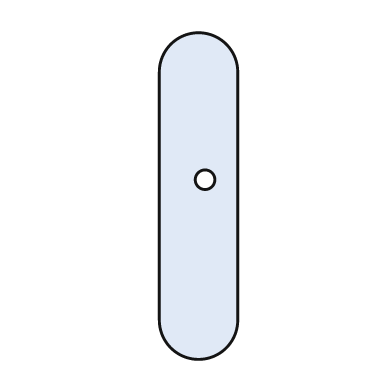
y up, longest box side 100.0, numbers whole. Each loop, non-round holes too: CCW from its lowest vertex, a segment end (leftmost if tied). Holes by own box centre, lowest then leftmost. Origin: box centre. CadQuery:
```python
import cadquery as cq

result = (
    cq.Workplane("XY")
    .moveTo(-12.0, -38.0)
    .threePointArc((0.0, -50.0), (12.0, -38.0))
    .lineTo(12.0, 38.0)
    .threePointArc((0.0, 50.0), (-12.0, 38.0))
    .close()
    .moveTo(2.0, 5.0)
    .circle(3.0)
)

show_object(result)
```